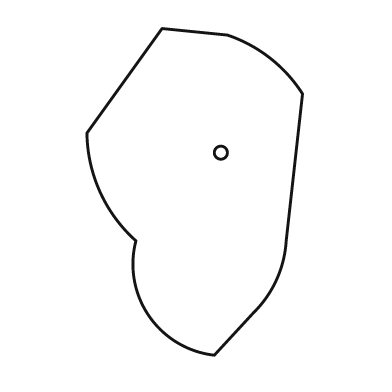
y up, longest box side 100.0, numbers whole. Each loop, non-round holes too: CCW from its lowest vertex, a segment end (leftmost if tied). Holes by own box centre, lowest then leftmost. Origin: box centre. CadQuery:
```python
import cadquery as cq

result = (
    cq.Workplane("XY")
    .moveTo(6.0, -50.0)
    .lineTo(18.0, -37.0)
    .threePointArc((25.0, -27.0), (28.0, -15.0))
    .lineTo(33.0, 30.0)
    .threePointArc((23.0, 41.0), (10.0, 48.0))
    .lineTo(-10.0, 50.0)
    .lineTo(-33.0, 18.0)
    .threePointArc((-29.0, 0.0), (-18.0, -15.0))
    .threePointArc((-14.0, -38.0), (6.0, -50.0))
    .close()
    .moveTo(8.0, 12.0)
    .circle(2.0)
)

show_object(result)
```